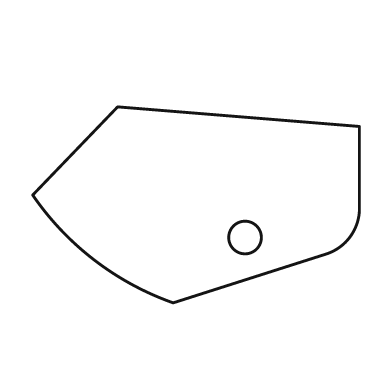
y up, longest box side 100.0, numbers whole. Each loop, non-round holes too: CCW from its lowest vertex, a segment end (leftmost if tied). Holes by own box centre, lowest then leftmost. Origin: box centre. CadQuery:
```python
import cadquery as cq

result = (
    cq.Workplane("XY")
    .moveTo(-7.0, -30.0)
    .lineTo(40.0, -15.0)
    .threePointArc((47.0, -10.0), (50.0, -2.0))
    .lineTo(50.0, 24.0)
    .lineTo(-24.0, 30.0)
    .lineTo(-50.0, 3.0)
    .threePointArc((-31.0, -17.0), (-7.0, -30.0))
    .close()
    .moveTo(15.0, -10.0)
    .circle(5.0)
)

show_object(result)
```